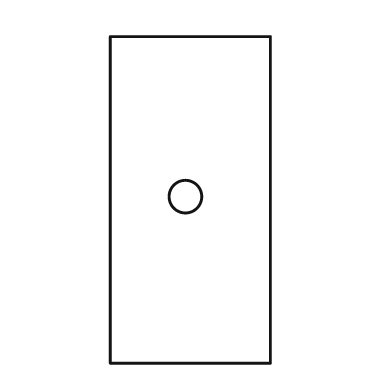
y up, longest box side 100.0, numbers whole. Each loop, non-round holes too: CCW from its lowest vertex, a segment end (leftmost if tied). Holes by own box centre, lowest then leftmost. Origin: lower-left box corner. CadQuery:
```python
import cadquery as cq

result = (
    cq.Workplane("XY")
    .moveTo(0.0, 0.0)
    .lineTo(49.0, 0.0)
    .lineTo(49.0, 100.0)
    .lineTo(0.0, 100.0)
    .close()
    .moveTo(23.0, 51.0)
    .circle(5.0)
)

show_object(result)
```